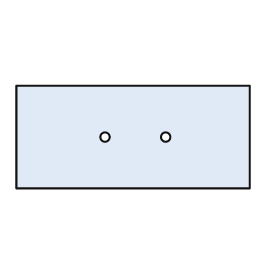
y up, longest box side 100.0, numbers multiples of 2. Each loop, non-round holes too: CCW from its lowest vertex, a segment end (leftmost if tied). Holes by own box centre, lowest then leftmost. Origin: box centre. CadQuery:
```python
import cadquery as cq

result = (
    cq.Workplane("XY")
    .moveTo(-50.0, -22.0)
    .lineTo(50.0, -22.0)
    .lineTo(50.0, 22.0)
    .lineTo(-50.0, 22.0)
    .close()
    .moveTo(-12.0, 0.0)
    .circle(2.0)
    .moveTo(14.0, 0.0)
    .circle(2.0)
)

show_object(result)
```